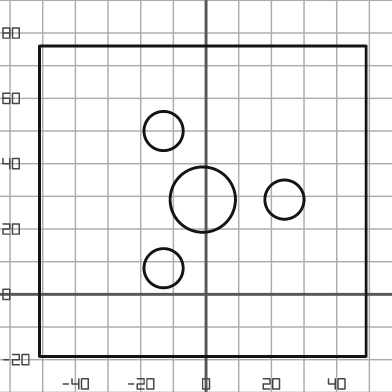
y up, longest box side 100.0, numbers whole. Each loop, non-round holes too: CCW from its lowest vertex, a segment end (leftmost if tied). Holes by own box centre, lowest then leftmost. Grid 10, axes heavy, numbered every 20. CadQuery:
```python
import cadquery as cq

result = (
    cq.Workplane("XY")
    .moveTo(-51.0, -19.0)
    .lineTo(49.0, -19.0)
    .lineTo(49.0, 76.0)
    .lineTo(-51.0, 76.0)
    .close()
    .moveTo(-13.0, 8.0)
    .circle(6.0)
    .moveTo(-1.0, 29.0)
    .circle(10.0)
    .moveTo(24.0, 29.0)
    .circle(6.0)
    .moveTo(-13.0, 50.0)
    .circle(6.0)
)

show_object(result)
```